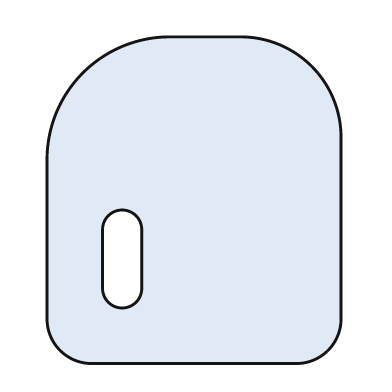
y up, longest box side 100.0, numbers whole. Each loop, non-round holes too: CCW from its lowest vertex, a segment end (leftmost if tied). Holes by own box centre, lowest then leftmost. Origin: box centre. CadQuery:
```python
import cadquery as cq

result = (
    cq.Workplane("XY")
    .moveTo(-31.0, -50.0)
    .lineTo(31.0, -50.0)
    .threePointArc((41.0, -46.0), (45.0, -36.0))
    .lineTo(45.0, 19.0)
    .threePointArc((36.0, 41.0), (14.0, 50.0))
    .lineTo(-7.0, 50.0)
    .threePointArc((-34.0, 39.0), (-45.0, 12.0))
    .lineTo(-45.0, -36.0)
    .threePointArc((-41.0, -46.0), (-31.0, -50.0))
    .close()
    .moveTo(-28.0, -27.0)
    .threePointArc((-22.0, -33.0), (-16.0, -27.0))
    .lineTo(-16.0, -9.0)
    .threePointArc((-22.0, -3.0), (-28.0, -9.0))
    .close()
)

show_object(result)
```